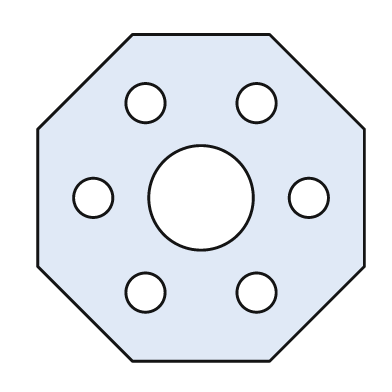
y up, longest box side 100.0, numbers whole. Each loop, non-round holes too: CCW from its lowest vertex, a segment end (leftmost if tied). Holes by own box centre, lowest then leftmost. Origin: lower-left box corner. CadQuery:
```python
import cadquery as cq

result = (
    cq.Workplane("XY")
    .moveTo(29.0, 0.0)
    .lineTo(71.0, 0.0)
    .lineTo(100.0, 29.0)
    .lineTo(100.0, 71.0)
    .lineTo(71.0, 100.0)
    .lineTo(29.0, 100.0)
    .lineTo(0.0, 71.0)
    .lineTo(0.0, 29.0)
    .close()
    .moveTo(33.0, 21.0)
    .circle(6.0)
    .moveTo(67.0, 21.0)
    .circle(6.0)
    .moveTo(17.0, 50.0)
    .circle(6.0)
    .moveTo(50.0, 50.0)
    .circle(16.0)
    .moveTo(83.0, 50.0)
    .circle(6.0)
    .moveTo(33.0, 79.0)
    .circle(6.0)
    .moveTo(67.0, 79.0)
    .circle(6.0)
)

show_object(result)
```